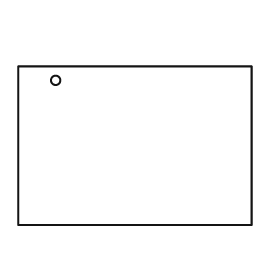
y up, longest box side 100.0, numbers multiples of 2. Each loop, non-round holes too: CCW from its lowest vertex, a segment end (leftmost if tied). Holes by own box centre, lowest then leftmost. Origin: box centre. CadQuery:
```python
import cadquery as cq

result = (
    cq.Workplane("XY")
    .moveTo(-50.0, -34.0)
    .lineTo(50.0, -34.0)
    .lineTo(50.0, 34.0)
    .lineTo(-50.0, 34.0)
    .close()
    .moveTo(-34.0, 28.0)
    .circle(2.0)
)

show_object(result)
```